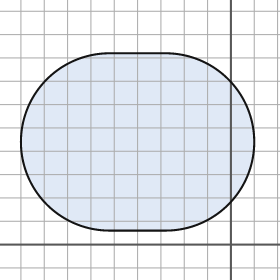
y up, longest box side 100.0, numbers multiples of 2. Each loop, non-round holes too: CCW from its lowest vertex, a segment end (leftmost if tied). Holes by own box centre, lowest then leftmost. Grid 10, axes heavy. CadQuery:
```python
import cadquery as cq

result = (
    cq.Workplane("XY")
    .moveTo(-52.0, 6.0)
    .lineTo(-28.0, 6.0)
    .threePointArc((10.0, 44.0), (-28.0, 82.0))
    .lineTo(-52.0, 82.0)
    .threePointArc((-90.0, 44.0), (-52.0, 6.0))
    .close()
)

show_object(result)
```